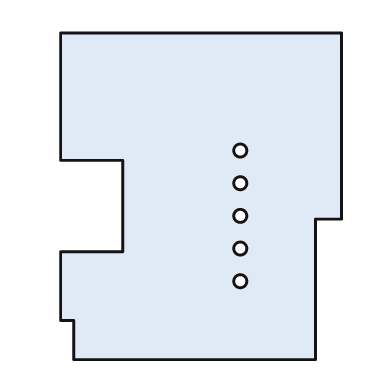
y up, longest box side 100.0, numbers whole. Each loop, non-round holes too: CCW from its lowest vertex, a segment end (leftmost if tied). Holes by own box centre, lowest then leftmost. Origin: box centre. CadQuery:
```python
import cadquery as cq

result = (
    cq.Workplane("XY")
    .moveTo(-39.0, -50.0)
    .lineTo(35.0, -50.0)
    .lineTo(35.0, -7.0)
    .lineTo(43.0, -7.0)
    .lineTo(43.0, 50.0)
    .lineTo(-43.0, 50.0)
    .lineTo(-43.0, 11.0)
    .lineTo(-24.0, 11.0)
    .lineTo(-24.0, -17.0)
    .lineTo(-43.0, -17.0)
    .lineTo(-43.0, -38.0)
    .lineTo(-39.0, -38.0)
    .close()
    .moveTo(12.0, -26.0)
    .circle(2.0)
    .moveTo(12.0, -16.0)
    .circle(2.0)
    .moveTo(12.0, -6.0)
    .circle(2.0)
    .moveTo(12.0, 4.0)
    .circle(2.0)
    .moveTo(12.0, 14.0)
    .circle(2.0)
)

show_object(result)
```